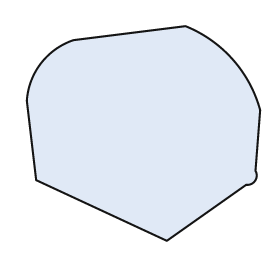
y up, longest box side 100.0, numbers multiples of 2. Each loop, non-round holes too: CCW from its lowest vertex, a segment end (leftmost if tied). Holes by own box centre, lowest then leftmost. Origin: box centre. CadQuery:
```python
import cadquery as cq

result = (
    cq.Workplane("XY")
    .moveTo(10.0, -46.0)
    .lineTo(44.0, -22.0)
    .threePointArc((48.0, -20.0), (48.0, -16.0))
    .lineTo(50.0, 10.0)
    .threePointArc((38.0, 32.0), (18.0, 46.0))
    .lineTo(-30.0, 40.0)
    .threePointArc((-44.0, 30.0), (-50.0, 14.0))
    .lineTo(-46.0, -20.0)
    .close()
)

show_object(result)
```